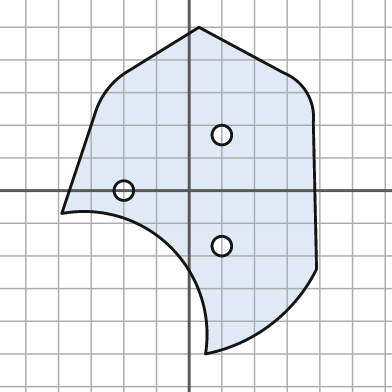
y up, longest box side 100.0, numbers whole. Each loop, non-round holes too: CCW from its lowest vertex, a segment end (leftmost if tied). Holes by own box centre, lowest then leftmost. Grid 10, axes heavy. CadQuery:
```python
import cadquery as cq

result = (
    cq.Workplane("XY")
    .moveTo(5.0, -50.0)
    .threePointArc((25.0, -41.0), (39.0, -24.0))
    .lineTo(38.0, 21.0)
    .threePointArc((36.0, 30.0), (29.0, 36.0))
    .lineTo(3.0, 50.0)
    .lineTo(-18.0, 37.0)
    .threePointArc((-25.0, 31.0), (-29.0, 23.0))
    .lineTo(-39.0, -7.0)
    .threePointArc((-6.0, -17.0), (5.0, -50.0))
    .close()
    .moveTo(10.0, -17.0)
    .circle(3.0)
    .moveTo(-20.0, 0.0)
    .circle(3.0)
    .moveTo(10.0, 17.0)
    .circle(3.0)
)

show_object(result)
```